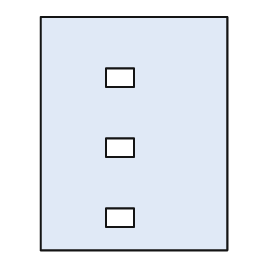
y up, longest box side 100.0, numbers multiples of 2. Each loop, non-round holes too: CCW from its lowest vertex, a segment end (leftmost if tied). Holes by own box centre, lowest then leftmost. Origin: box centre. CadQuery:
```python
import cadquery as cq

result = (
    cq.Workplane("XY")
    .moveTo(-40.0, -50.0)
    .lineTo(40.0, -50.0)
    .lineTo(40.0, 50.0)
    .lineTo(-40.0, 50.0)
    .close()
    .moveTo(-12.0, -40.0)
    .lineTo(0.0, -40.0)
    .lineTo(0.0, -32.0)
    .lineTo(-12.0, -32.0)
    .close()
    .moveTo(-12.0, -10.0)
    .lineTo(0.0, -10.0)
    .lineTo(0.0, -2.0)
    .lineTo(-12.0, -2.0)
    .close()
    .moveTo(-12.0, 20.0)
    .lineTo(0.0, 20.0)
    .lineTo(0.0, 28.0)
    .lineTo(-12.0, 28.0)
    .close()
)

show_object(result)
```